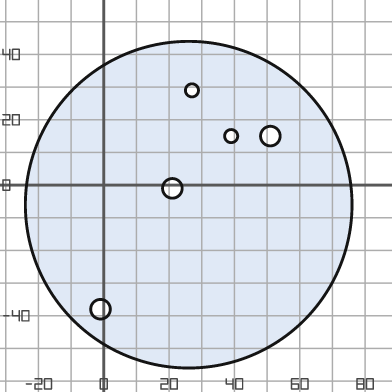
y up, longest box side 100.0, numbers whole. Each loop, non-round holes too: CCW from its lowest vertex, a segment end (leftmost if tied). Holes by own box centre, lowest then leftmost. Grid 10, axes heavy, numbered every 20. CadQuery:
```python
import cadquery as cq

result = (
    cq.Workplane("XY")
    .moveTo(26.0, -6.0)
    .circle(50.0)
    .moveTo(-1.0, -38.0)
    .circle(3.0)
    .moveTo(21.0, -1.0)
    .circle(3.0)
    .moveTo(39.0, 15.0)
    .circle(2.0)
    .moveTo(51.0, 15.0)
    .circle(3.0)
    .moveTo(27.0, 29.0)
    .circle(2.0)
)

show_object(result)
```